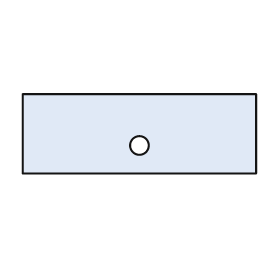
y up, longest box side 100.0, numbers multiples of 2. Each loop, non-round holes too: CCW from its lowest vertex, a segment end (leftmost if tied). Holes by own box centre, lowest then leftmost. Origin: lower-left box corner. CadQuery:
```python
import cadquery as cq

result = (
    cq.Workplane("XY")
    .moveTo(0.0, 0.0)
    .lineTo(100.0, 0.0)
    .lineTo(100.0, 34.0)
    .lineTo(0.0, 34.0)
    .close()
    .moveTo(50.0, 12.0)
    .circle(4.0)
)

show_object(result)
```